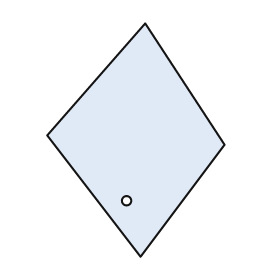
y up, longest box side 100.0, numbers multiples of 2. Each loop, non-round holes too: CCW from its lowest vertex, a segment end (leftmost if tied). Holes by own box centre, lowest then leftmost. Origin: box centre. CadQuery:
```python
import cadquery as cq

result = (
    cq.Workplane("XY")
    .moveTo(2.0, -50.0)
    .lineTo(38.0, -2.0)
    .lineTo(4.0, 50.0)
    .lineTo(-38.0, 2.0)
    .close()
    .moveTo(-4.0, -26.0)
    .circle(2.0)
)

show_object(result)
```